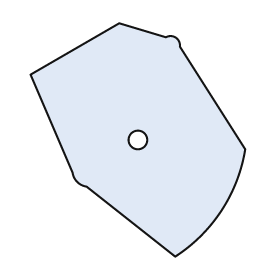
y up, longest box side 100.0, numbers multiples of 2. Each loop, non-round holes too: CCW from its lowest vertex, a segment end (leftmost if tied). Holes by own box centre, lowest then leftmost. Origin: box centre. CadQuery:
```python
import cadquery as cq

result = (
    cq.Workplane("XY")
    .moveTo(16.0, -50.0)
    .threePointArc((36.0, -30.0), (46.0, -4.0))
    .lineTo(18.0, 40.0)
    .threePointArc((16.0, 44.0), (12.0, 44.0))
    .lineTo(-8.0, 50.0)
    .lineTo(-46.0, 28.0)
    .lineTo(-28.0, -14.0)
    .threePointArc((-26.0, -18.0), (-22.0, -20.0))
    .close()
    .moveTo(0.0, 0.0)
    .circle(4.0)
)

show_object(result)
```